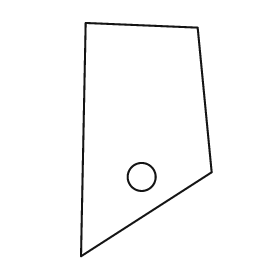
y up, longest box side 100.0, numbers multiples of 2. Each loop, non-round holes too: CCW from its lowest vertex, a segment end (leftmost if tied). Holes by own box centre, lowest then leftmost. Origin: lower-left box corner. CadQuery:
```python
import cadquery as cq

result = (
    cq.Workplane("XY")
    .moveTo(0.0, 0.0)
    .lineTo(56.0, 36.0)
    .lineTo(50.0, 98.0)
    .lineTo(2.0, 100.0)
    .close()
    .moveTo(26.0, 34.0)
    .circle(6.0)
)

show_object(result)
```